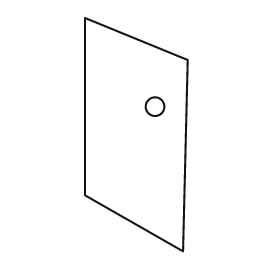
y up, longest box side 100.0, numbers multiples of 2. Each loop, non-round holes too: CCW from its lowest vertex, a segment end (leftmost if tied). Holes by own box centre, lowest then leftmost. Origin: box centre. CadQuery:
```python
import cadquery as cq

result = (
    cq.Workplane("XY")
    .moveTo(20.0, -50.0)
    .lineTo(22.0, 32.0)
    .lineTo(-22.0, 50.0)
    .lineTo(-22.0, -26.0)
    .close()
    .moveTo(8.0, 12.0)
    .circle(4.0)
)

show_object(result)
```